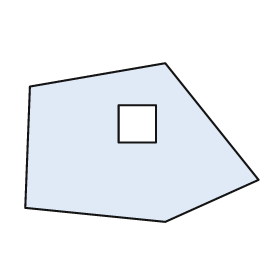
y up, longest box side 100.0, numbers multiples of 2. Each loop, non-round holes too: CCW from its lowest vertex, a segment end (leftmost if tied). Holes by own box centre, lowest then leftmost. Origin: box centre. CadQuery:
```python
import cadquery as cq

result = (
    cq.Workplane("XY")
    .moveTo(10.0, -34.0)
    .lineTo(50.0, -16.0)
    .lineTo(10.0, 34.0)
    .lineTo(-48.0, 24.0)
    .lineTo(-50.0, -28.0)
    .close()
    .moveTo(-10.0, 0.0)
    .lineTo(6.0, 0.0)
    .lineTo(6.0, 16.0)
    .lineTo(-10.0, 16.0)
    .close()
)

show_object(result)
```